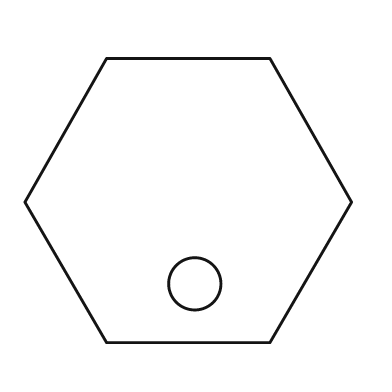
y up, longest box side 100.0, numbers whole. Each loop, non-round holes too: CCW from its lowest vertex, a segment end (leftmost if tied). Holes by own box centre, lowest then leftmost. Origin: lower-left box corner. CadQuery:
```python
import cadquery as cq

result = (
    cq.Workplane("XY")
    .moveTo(25.0, 0.0)
    .lineTo(75.0, 0.0)
    .lineTo(100.0, 43.0)
    .lineTo(75.0, 87.0)
    .lineTo(25.0, 87.0)
    .lineTo(0.0, 43.0)
    .close()
    .moveTo(52.0, 18.0)
    .circle(8.0)
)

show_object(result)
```